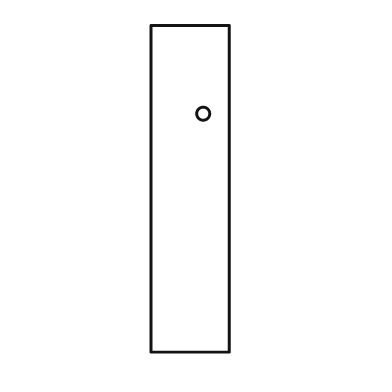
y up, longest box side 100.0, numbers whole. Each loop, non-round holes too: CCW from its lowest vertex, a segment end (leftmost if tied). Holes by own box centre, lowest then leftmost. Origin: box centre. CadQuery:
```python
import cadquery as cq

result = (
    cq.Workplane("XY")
    .moveTo(-12.0, -50.0)
    .lineTo(12.0, -50.0)
    .lineTo(12.0, 50.0)
    .lineTo(-12.0, 50.0)
    .close()
    .moveTo(4.0, 23.0)
    .circle(2.0)
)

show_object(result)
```